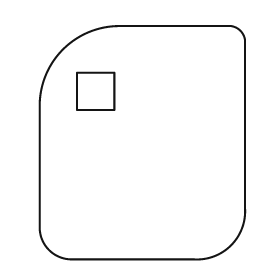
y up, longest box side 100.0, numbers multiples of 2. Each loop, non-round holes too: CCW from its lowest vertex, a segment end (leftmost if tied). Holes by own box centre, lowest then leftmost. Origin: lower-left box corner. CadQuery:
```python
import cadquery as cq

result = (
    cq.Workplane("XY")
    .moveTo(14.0, 0.0)
    .lineTo(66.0, 0.0)
    .threePointArc((82.0, 6.0), (88.0, 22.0))
    .lineTo(88.0, 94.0)
    .threePointArc((86.0, 98.0), (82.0, 100.0))
    .lineTo(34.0, 100.0)
    .threePointArc((10.0, 90.0), (0.0, 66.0))
    .lineTo(0.0, 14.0)
    .threePointArc((4.0, 4.0), (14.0, 0.0))
    .close()
    .moveTo(16.0, 64.0)
    .lineTo(32.0, 64.0)
    .lineTo(32.0, 80.0)
    .lineTo(16.0, 80.0)
    .close()
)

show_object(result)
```